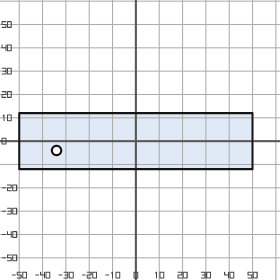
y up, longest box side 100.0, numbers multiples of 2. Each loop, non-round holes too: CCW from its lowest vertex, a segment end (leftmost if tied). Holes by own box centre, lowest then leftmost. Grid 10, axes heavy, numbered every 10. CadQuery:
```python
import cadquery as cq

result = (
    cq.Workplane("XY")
    .moveTo(-50.0, -12.0)
    .lineTo(50.0, -12.0)
    .lineTo(50.0, 12.0)
    .lineTo(-50.0, 12.0)
    .close()
    .moveTo(-34.0, -4.0)
    .circle(2.0)
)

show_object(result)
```